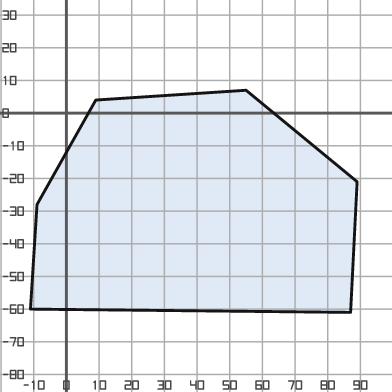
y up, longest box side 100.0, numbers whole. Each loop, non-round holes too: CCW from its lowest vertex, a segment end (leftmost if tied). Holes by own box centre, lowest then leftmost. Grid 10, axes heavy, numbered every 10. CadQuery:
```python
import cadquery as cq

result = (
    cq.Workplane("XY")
    .moveTo(87.0, -61.0)
    .lineTo(89.0, -21.0)
    .lineTo(55.0, 7.0)
    .lineTo(9.0, 4.0)
    .lineTo(-9.0, -28.0)
    .lineTo(-11.0, -60.0)
    .close()
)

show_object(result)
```